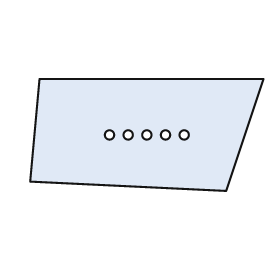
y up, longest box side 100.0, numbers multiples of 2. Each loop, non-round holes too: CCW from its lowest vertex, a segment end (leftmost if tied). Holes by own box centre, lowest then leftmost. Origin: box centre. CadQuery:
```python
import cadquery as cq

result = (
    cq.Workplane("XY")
    .moveTo(34.0, -24.0)
    .lineTo(50.0, 24.0)
    .lineTo(-46.0, 24.0)
    .lineTo(-50.0, -20.0)
    .close()
    .moveTo(-16.0, 0.0)
    .circle(2.0)
    .moveTo(-8.0, 0.0)
    .circle(2.0)
    .moveTo(0.0, 0.0)
    .circle(2.0)
    .moveTo(8.0, 0.0)
    .circle(2.0)
    .moveTo(16.0, 0.0)
    .circle(2.0)
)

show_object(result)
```